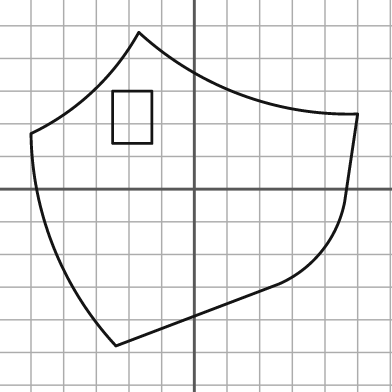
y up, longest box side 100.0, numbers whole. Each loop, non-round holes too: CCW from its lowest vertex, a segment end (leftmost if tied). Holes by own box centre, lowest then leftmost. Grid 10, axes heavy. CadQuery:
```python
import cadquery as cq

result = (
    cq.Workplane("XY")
    .moveTo(-24.0, -48.0)
    .lineTo(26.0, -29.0)
    .threePointArc((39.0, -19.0), (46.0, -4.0))
    .lineTo(50.0, 23.0)
    .threePointArc((14.0, 29.0), (-17.0, 48.0))
    .threePointArc((-31.0, 30.0), (-50.0, 17.0))
    .threePointArc((-43.0, -18.0), (-24.0, -48.0))
    .close()
    .moveTo(-25.0, 14.0)
    .lineTo(-13.0, 14.0)
    .lineTo(-13.0, 30.0)
    .lineTo(-25.0, 30.0)
    .close()
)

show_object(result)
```